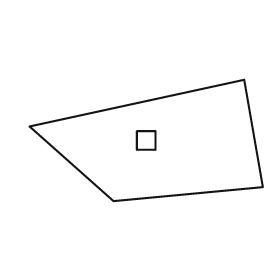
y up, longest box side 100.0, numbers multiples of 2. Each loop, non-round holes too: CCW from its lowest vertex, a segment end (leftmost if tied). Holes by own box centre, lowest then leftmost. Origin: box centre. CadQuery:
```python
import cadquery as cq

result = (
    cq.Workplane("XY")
    .moveTo(-14.0, -26.0)
    .lineTo(50.0, -20.0)
    .lineTo(42.0, 26.0)
    .lineTo(-50.0, 6.0)
    .close()
    .moveTo(-4.0, -4.0)
    .lineTo(4.0, -4.0)
    .lineTo(4.0, 4.0)
    .lineTo(-4.0, 4.0)
    .close()
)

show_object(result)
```